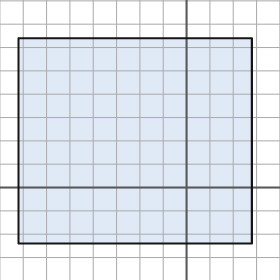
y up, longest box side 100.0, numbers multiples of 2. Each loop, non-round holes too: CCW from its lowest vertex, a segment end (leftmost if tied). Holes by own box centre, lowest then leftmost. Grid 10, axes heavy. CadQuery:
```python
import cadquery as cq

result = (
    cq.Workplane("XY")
    .moveTo(-72.0, -24.0)
    .lineTo(28.0, -24.0)
    .lineTo(28.0, 64.0)
    .lineTo(-72.0, 64.0)
    .close()
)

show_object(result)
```